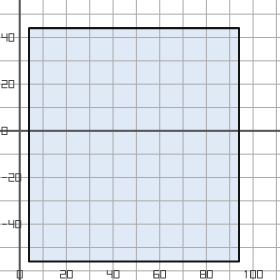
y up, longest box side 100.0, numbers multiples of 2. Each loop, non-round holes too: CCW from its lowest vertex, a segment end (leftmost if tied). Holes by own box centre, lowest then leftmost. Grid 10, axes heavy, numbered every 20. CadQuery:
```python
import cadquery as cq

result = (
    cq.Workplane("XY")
    .moveTo(4.0, -56.0)
    .lineTo(94.0, -56.0)
    .lineTo(94.0, 44.0)
    .lineTo(4.0, 44.0)
    .close()
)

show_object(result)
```